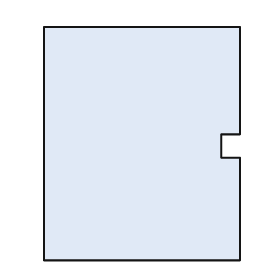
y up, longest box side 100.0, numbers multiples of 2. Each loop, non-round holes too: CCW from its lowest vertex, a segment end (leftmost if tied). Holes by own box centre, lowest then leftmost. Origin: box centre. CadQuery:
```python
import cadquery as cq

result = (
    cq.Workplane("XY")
    .moveTo(-42.0, -50.0)
    .lineTo(42.0, -50.0)
    .lineTo(42.0, -6.0)
    .lineTo(34.0, -6.0)
    .lineTo(34.0, 4.0)
    .lineTo(42.0, 4.0)
    .lineTo(42.0, 50.0)
    .lineTo(-42.0, 50.0)
    .close()
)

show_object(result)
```